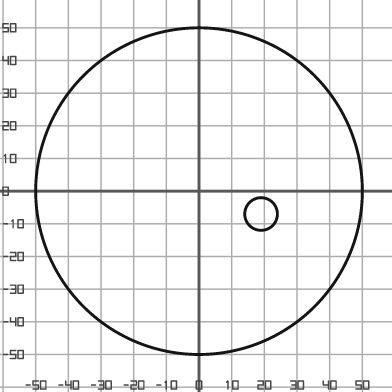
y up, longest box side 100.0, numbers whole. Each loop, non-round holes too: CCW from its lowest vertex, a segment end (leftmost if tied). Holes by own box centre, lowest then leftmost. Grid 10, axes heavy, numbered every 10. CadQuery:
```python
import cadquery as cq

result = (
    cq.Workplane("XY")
    .moveTo(0.0, 0.0)
    .circle(50.0)
    .moveTo(19.0, -7.0)
    .circle(5.0)
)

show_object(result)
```